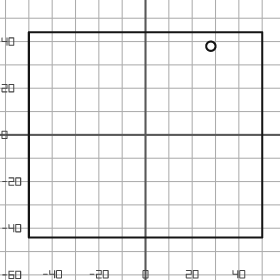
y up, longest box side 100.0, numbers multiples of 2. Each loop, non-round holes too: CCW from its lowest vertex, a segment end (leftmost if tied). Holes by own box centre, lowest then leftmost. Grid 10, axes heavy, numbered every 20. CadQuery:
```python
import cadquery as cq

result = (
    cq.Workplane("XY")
    .moveTo(-50.0, -44.0)
    .lineTo(50.0, -44.0)
    .lineTo(50.0, 44.0)
    .lineTo(-50.0, 44.0)
    .close()
    .moveTo(28.0, 38.0)
    .circle(2.0)
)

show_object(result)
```